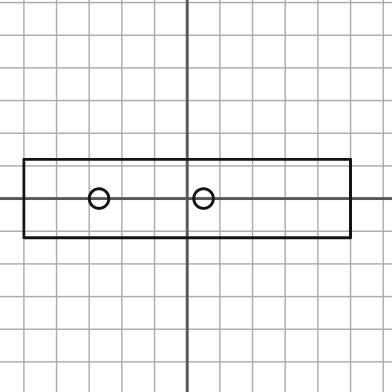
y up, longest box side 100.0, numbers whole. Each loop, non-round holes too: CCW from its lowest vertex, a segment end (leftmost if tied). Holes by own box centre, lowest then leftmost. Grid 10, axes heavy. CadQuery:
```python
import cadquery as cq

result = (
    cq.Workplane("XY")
    .moveTo(-50.0, -12.0)
    .lineTo(50.0, -12.0)
    .lineTo(50.0, 12.0)
    .lineTo(-50.0, 12.0)
    .close()
    .moveTo(-27.0, 0.0)
    .circle(3.0)
    .moveTo(5.0, 0.0)
    .circle(3.0)
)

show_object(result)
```